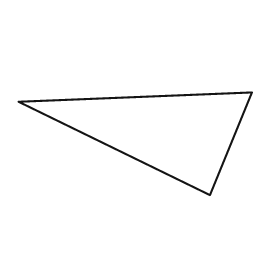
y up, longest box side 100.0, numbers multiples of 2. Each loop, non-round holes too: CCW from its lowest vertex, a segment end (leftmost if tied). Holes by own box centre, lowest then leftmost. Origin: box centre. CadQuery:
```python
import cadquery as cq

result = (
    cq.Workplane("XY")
    .moveTo(32.0, -22.0)
    .lineTo(50.0, 22.0)
    .lineTo(-50.0, 18.0)
    .close()
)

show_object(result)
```